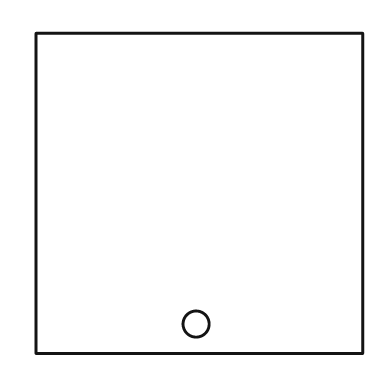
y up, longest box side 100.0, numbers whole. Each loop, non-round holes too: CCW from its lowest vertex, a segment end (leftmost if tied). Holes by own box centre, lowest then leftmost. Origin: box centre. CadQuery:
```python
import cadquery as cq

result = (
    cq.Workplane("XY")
    .moveTo(-50.0, -49.0)
    .lineTo(50.0, -49.0)
    .lineTo(50.0, 49.0)
    .lineTo(-50.0, 49.0)
    .close()
    .moveTo(-1.0, -40.0)
    .circle(4.0)
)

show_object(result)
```